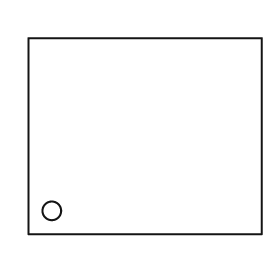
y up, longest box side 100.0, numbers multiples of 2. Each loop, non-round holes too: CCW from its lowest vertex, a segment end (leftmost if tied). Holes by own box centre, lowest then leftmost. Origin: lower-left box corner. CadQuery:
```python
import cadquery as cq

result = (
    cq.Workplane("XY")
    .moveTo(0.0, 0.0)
    .lineTo(100.0, 0.0)
    .lineTo(100.0, 84.0)
    .lineTo(0.0, 84.0)
    .close()
    .moveTo(10.0, 10.0)
    .circle(4.0)
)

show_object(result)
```